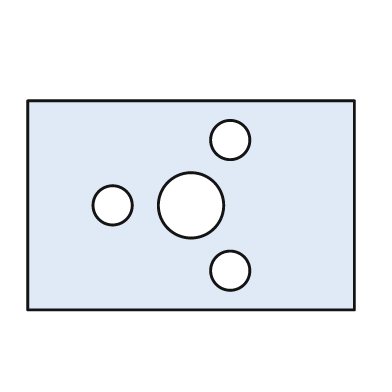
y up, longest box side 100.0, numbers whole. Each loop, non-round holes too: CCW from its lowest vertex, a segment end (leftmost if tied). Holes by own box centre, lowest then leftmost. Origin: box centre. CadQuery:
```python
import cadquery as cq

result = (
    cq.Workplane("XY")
    .moveTo(-50.0, -32.0)
    .lineTo(50.0, -32.0)
    .lineTo(50.0, 32.0)
    .lineTo(-50.0, 32.0)
    .close()
    .moveTo(12.0, -20.0)
    .circle(6.0)
    .moveTo(-24.0, 0.0)
    .circle(6.0)
    .moveTo(0.0, 0.0)
    .circle(10.0)
    .moveTo(12.0, 20.0)
    .circle(6.0)
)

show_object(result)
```